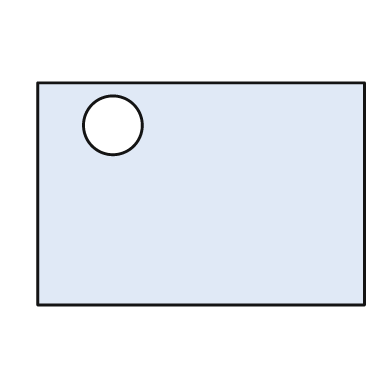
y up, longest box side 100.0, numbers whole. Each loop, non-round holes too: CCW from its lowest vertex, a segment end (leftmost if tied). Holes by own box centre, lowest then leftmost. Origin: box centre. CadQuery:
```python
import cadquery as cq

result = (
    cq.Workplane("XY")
    .moveTo(-50.0, -34.0)
    .lineTo(50.0, -34.0)
    .lineTo(50.0, 34.0)
    .lineTo(-50.0, 34.0)
    .close()
    .moveTo(-27.0, 21.0)
    .circle(9.0)
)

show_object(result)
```